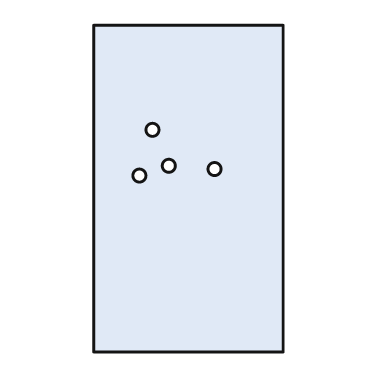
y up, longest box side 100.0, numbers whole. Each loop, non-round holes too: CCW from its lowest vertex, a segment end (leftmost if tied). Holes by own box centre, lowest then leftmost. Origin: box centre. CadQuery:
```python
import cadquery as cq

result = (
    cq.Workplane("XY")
    .moveTo(-29.0, -50.0)
    .lineTo(29.0, -50.0)
    .lineTo(29.0, 50.0)
    .lineTo(-29.0, 50.0)
    .close()
    .moveTo(-15.0, 4.0)
    .circle(2.0)
    .moveTo(8.0, 6.0)
    .circle(2.0)
    .moveTo(-6.0, 7.0)
    .circle(2.0)
    .moveTo(-11.0, 18.0)
    .circle(2.0)
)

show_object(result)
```